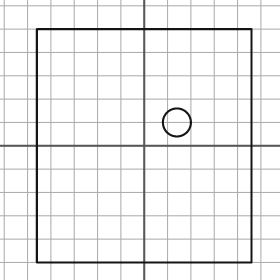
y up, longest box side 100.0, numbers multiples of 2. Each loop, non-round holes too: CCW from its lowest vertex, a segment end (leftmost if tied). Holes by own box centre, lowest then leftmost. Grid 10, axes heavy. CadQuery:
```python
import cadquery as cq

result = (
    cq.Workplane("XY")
    .moveTo(-46.0, -50.0)
    .lineTo(46.0, -50.0)
    .lineTo(46.0, 50.0)
    .lineTo(-46.0, 50.0)
    .close()
    .moveTo(14.0, 10.0)
    .circle(6.0)
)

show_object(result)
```